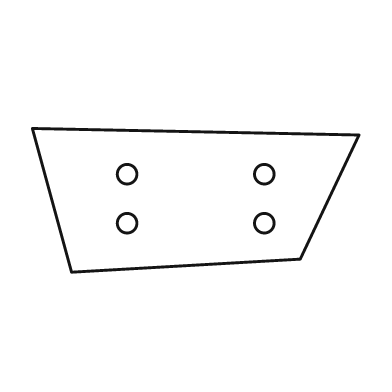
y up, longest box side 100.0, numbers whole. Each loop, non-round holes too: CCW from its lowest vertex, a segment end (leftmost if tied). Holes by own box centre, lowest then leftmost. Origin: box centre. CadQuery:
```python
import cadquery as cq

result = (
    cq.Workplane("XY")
    .moveTo(-38.0, -22.0)
    .lineTo(32.0, -18.0)
    .lineTo(50.0, 20.0)
    .lineTo(-50.0, 22.0)
    .close()
    .moveTo(-21.0, -7.0)
    .circle(3.0)
    .moveTo(21.0, -7.0)
    .circle(3.0)
    .moveTo(-21.0, 8.0)
    .circle(3.0)
    .moveTo(21.0, 8.0)
    .circle(3.0)
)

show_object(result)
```